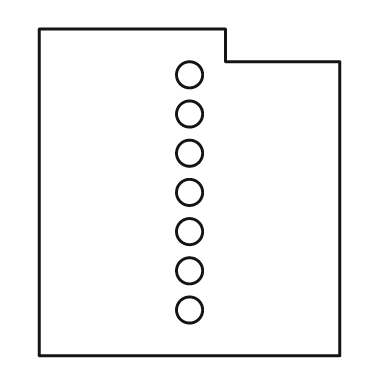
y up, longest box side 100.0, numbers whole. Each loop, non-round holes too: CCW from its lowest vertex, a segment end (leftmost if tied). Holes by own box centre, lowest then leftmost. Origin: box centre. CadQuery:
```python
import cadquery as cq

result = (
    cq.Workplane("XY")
    .moveTo(-46.0, -50.0)
    .lineTo(46.0, -50.0)
    .lineTo(46.0, 40.0)
    .lineTo(11.0, 40.0)
    .lineTo(11.0, 50.0)
    .lineTo(-46.0, 50.0)
    .close()
    .moveTo(0.0, -36.0)
    .circle(4.0)
    .moveTo(0.0, -24.0)
    .circle(4.0)
    .moveTo(0.0, -12.0)
    .circle(4.0)
    .moveTo(0.0, 0.0)
    .circle(4.0)
    .moveTo(0.0, 12.0)
    .circle(4.0)
    .moveTo(0.0, 24.0)
    .circle(4.0)
    .moveTo(0.0, 36.0)
    .circle(4.0)
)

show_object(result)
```